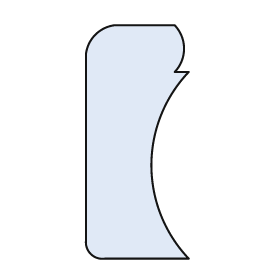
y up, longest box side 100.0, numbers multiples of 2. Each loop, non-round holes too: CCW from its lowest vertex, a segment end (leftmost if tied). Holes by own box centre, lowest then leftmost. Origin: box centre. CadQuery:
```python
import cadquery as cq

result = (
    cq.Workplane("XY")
    .moveTo(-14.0, -50.0)
    .lineTo(22.0, -50.0)
    .threePointArc((6.0, -10.0), (22.0, 30.0))
    .lineTo(16.0, 30.0)
    .threePointArc((20.0, 40.0), (16.0, 50.0))
    .lineTo(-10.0, 50.0)
    .threePointArc((-18.0, 46.0), (-22.0, 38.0))
    .lineTo(-22.0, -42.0)
    .threePointArc((-20.0, -48.0), (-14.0, -50.0))
    .close()
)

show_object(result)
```